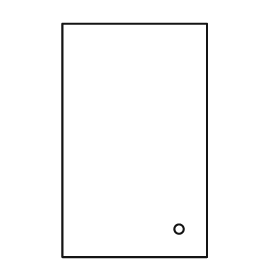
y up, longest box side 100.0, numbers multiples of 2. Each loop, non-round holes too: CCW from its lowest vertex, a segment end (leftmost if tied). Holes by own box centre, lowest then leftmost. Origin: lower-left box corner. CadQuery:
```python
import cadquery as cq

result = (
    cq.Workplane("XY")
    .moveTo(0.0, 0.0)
    .lineTo(62.0, 0.0)
    .lineTo(62.0, 100.0)
    .lineTo(0.0, 100.0)
    .close()
    .moveTo(50.0, 12.0)
    .circle(2.0)
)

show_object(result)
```